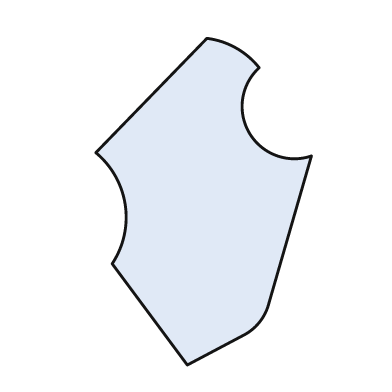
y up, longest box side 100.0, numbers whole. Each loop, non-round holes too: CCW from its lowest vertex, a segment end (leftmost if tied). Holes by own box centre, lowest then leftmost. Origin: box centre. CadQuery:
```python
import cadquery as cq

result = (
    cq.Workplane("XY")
    .moveTo(-5.0, -50.0)
    .lineTo(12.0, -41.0)
    .threePointArc((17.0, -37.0), (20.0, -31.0))
    .lineTo(33.0, 14.0)
    .threePointArc((14.0, 21.0), (17.0, 41.0))
    .threePointArc((10.0, 47.0), (1.0, 50.0))
    .lineTo(-33.0, 15.0)
    .threePointArc((-24.0, -1.0), (-28.0, -19.0))
    .close()
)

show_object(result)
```